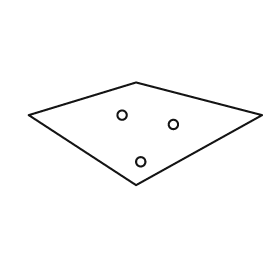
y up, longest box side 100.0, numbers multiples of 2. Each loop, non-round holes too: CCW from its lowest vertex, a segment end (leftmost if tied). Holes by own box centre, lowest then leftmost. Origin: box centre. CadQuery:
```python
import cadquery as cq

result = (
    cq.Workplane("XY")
    .moveTo(-4.0, -22.0)
    .lineTo(50.0, 8.0)
    .lineTo(-4.0, 22.0)
    .lineTo(-50.0, 8.0)
    .close()
    .moveTo(-2.0, -12.0)
    .circle(2.0)
    .moveTo(12.0, 4.0)
    .circle(2.0)
    .moveTo(-10.0, 8.0)
    .circle(2.0)
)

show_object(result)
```